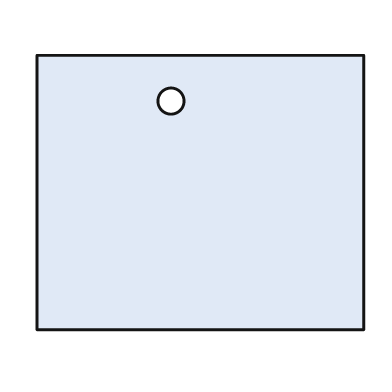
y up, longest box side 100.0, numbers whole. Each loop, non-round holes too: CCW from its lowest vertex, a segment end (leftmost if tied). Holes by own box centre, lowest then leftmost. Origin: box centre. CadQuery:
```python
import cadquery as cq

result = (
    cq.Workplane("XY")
    .moveTo(-50.0, -42.0)
    .lineTo(50.0, -42.0)
    .lineTo(50.0, 42.0)
    .lineTo(-50.0, 42.0)
    .close()
    .moveTo(-9.0, 28.0)
    .circle(4.0)
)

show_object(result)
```